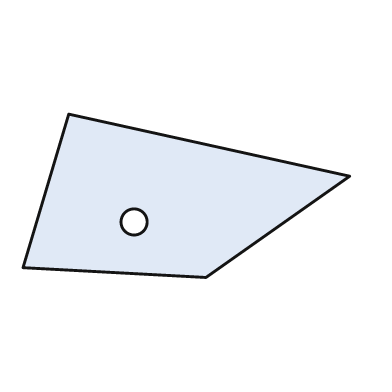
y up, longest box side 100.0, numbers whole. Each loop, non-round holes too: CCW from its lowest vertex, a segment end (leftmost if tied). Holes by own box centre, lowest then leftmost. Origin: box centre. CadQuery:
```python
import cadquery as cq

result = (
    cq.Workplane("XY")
    .moveTo(6.0, -25.0)
    .lineTo(50.0, 6.0)
    .lineTo(-36.0, 25.0)
    .lineTo(-50.0, -22.0)
    .close()
    .moveTo(-16.0, -8.0)
    .circle(4.0)
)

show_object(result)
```